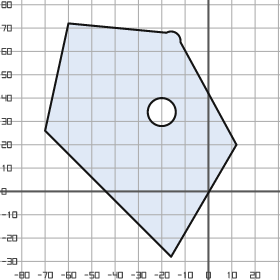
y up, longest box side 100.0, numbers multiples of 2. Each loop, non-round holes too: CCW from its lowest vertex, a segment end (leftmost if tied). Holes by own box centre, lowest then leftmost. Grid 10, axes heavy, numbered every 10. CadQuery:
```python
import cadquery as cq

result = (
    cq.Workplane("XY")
    .moveTo(-16.0, -28.0)
    .lineTo(12.0, 20.0)
    .lineTo(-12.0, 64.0)
    .threePointArc((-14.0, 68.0), (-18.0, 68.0))
    .lineTo(-60.0, 72.0)
    .lineTo(-70.0, 26.0)
    .close()
    .moveTo(-20.0, 34.0)
    .circle(6.0)
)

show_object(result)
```